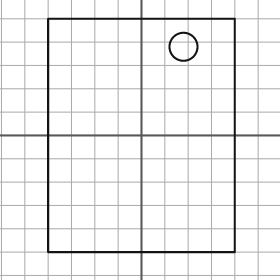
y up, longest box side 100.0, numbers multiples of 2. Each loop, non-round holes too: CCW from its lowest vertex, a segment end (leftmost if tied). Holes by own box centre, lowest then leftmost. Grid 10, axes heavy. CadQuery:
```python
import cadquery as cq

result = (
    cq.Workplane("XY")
    .moveTo(-40.0, -50.0)
    .lineTo(40.0, -50.0)
    .lineTo(40.0, 50.0)
    .lineTo(-40.0, 50.0)
    .close()
    .moveTo(18.0, 38.0)
    .circle(6.0)
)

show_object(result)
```